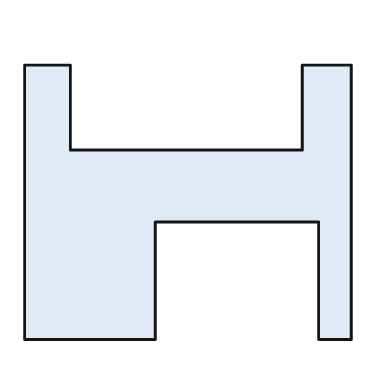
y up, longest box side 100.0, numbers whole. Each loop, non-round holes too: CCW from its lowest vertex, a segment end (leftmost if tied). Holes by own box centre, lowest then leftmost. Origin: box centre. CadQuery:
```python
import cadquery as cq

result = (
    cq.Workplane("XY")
    .moveTo(-50.0, -42.0)
    .lineTo(-10.0, -42.0)
    .lineTo(-10.0, -6.0)
    .lineTo(40.0, -6.0)
    .lineTo(40.0, -42.0)
    .lineTo(50.0, -42.0)
    .lineTo(50.0, 42.0)
    .lineTo(35.0, 42.0)
    .lineTo(35.0, 16.0)
    .lineTo(-36.0, 16.0)
    .lineTo(-36.0, 42.0)
    .lineTo(-50.0, 42.0)
    .close()
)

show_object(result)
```